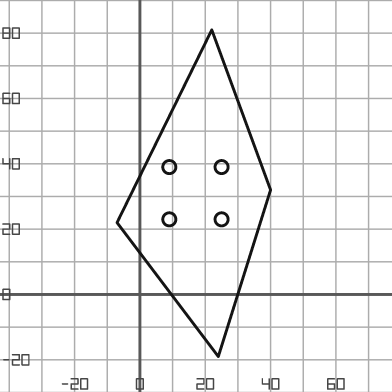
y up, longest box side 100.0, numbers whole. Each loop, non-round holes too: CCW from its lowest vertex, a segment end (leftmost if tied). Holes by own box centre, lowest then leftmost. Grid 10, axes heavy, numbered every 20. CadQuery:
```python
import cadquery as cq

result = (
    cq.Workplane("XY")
    .moveTo(24.0, -19.0)
    .lineTo(40.0, 32.0)
    .lineTo(22.0, 81.0)
    .lineTo(-7.0, 22.0)
    .close()
    .moveTo(9.0, 23.0)
    .circle(2.0)
    .moveTo(25.0, 23.0)
    .circle(2.0)
    .moveTo(9.0, 39.0)
    .circle(2.0)
    .moveTo(25.0, 39.0)
    .circle(2.0)
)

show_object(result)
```